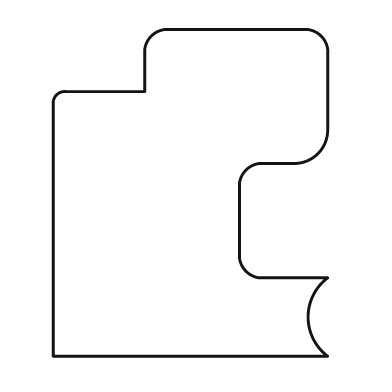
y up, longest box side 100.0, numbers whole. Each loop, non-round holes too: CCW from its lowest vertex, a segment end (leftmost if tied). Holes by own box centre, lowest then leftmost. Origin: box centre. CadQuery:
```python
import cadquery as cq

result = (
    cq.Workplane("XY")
    .moveTo(-42.0, -50.0)
    .lineTo(42.0, -50.0)
    .threePointArc((36.0, -38.0), (42.0, -26.0))
    .lineTo(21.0, -26.0)
    .threePointArc((17.0, -24.0), (15.0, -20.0))
    .lineTo(15.0, 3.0)
    .threePointArc((17.0, 7.0), (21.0, 9.0))
    .lineTo(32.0, 9.0)
    .threePointArc((39.0, 12.0), (42.0, 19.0))
    .lineTo(42.0, 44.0)
    .threePointArc((40.0, 48.0), (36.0, 50.0))
    .lineTo(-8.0, 50.0)
    .threePointArc((-12.0, 48.0), (-14.0, 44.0))
    .lineTo(-14.0, 31.0)
    .lineTo(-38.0, 31.0)
    .threePointArc((-41.0, 30.0), (-42.0, 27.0))
    .close()
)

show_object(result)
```